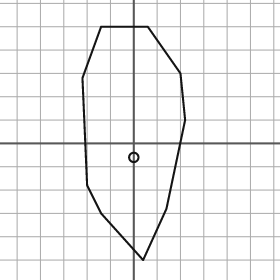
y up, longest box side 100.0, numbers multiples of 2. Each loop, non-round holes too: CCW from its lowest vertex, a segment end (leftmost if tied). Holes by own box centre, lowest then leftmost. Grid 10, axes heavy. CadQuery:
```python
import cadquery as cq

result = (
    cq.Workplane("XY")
    .moveTo(4.0, -50.0)
    .lineTo(14.0, -28.0)
    .lineTo(22.0, 10.0)
    .lineTo(20.0, 30.0)
    .lineTo(6.0, 50.0)
    .lineTo(-14.0, 50.0)
    .lineTo(-22.0, 28.0)
    .lineTo(-20.0, -18.0)
    .lineTo(-14.0, -30.0)
    .close()
    .moveTo(0.0, -6.0)
    .circle(2.0)
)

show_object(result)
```